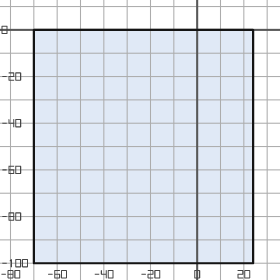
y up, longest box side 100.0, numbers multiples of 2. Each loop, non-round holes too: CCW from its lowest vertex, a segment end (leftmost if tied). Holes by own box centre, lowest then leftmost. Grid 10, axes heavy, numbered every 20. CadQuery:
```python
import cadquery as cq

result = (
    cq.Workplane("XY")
    .moveTo(-70.0, -100.0)
    .lineTo(24.0, -100.0)
    .lineTo(24.0, 0.0)
    .lineTo(-70.0, 0.0)
    .close()
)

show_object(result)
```